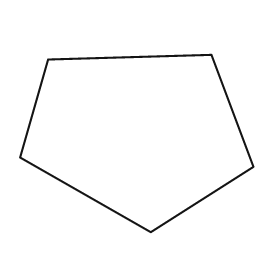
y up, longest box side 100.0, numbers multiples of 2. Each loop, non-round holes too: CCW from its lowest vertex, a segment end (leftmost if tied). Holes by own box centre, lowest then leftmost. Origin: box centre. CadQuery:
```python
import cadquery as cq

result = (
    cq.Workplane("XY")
    .moveTo(6.0, -38.0)
    .lineTo(50.0, -10.0)
    .lineTo(32.0, 38.0)
    .lineTo(-38.0, 36.0)
    .lineTo(-50.0, -6.0)
    .close()
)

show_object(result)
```